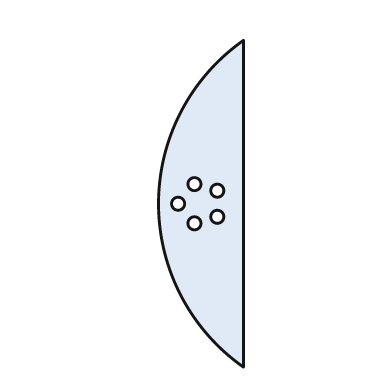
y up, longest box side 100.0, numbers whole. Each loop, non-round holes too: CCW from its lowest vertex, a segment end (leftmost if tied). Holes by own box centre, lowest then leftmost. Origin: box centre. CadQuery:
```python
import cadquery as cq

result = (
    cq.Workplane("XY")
    .moveTo(13.0, -50.0)
    .lineTo(13.0, 50.0)
    .threePointArc((-13.0, 0.0), (13.0, -50.0))
    .close()
    .moveTo(-2.0, -6.0)
    .circle(2.0)
    .moveTo(5.0, -4.0)
    .circle(2.0)
    .moveTo(-7.0, 0.0)
    .circle(2.0)
    .moveTo(5.0, 4.0)
    .circle(2.0)
    .moveTo(-2.0, 6.0)
    .circle(2.0)
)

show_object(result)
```